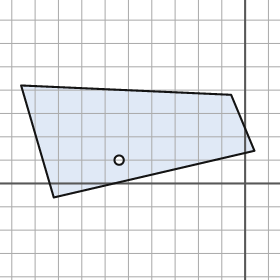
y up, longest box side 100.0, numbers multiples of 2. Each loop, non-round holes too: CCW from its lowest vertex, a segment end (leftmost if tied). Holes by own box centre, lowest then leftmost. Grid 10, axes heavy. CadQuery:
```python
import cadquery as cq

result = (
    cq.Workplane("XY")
    .moveTo(-82.0, -6.0)
    .lineTo(4.0, 14.0)
    .lineTo(-6.0, 38.0)
    .lineTo(-96.0, 42.0)
    .close()
    .moveTo(-54.0, 10.0)
    .circle(2.0)
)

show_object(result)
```